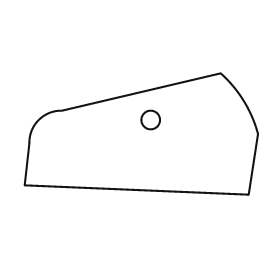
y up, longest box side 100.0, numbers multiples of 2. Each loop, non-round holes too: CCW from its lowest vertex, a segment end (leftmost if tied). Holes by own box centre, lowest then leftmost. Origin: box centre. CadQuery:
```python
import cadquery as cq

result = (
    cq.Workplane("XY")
    .moveTo(46.0, -26.0)
    .lineTo(50.0, 0.0)
    .threePointArc((44.0, 14.0), (34.0, 26.0))
    .lineTo(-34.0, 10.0)
    .threePointArc((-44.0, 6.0), (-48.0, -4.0))
    .lineTo(-50.0, -22.0)
    .close()
    .moveTo(4.0, 6.0)
    .circle(4.0)
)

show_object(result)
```